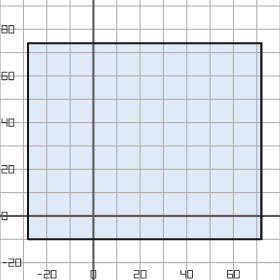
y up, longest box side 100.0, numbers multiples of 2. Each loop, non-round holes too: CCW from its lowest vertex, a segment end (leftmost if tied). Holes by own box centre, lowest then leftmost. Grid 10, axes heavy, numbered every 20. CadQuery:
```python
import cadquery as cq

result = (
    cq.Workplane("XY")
    .moveTo(-28.0, -10.0)
    .lineTo(72.0, -10.0)
    .lineTo(72.0, 74.0)
    .lineTo(-28.0, 74.0)
    .close()
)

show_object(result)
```